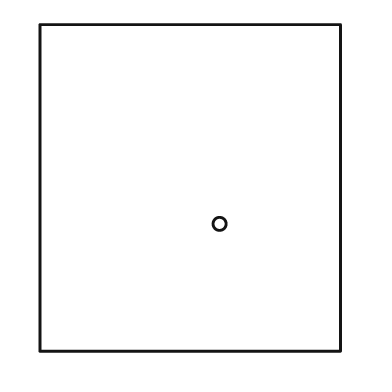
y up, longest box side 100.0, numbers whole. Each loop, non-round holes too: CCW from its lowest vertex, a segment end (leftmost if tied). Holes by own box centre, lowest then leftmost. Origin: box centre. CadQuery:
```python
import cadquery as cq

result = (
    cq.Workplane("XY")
    .moveTo(-46.0, -50.0)
    .lineTo(46.0, -50.0)
    .lineTo(46.0, 50.0)
    .lineTo(-46.0, 50.0)
    .close()
    .moveTo(9.0, -11.0)
    .circle(2.0)
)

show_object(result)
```